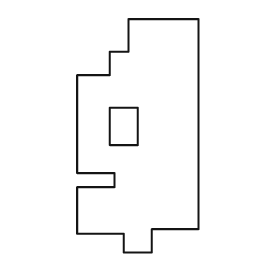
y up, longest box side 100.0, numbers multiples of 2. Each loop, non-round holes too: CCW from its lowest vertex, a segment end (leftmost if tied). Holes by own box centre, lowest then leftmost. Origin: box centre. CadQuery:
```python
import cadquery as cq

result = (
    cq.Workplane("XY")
    .moveTo(-6.0, -50.0)
    .lineTo(6.0, -50.0)
    .lineTo(6.0, -40.0)
    .lineTo(26.0, -40.0)
    .lineTo(26.0, 50.0)
    .lineTo(-4.0, 50.0)
    .lineTo(-4.0, 36.0)
    .lineTo(-12.0, 36.0)
    .lineTo(-12.0, 26.0)
    .lineTo(-26.0, 26.0)
    .lineTo(-26.0, -16.0)
    .lineTo(-10.0, -16.0)
    .lineTo(-10.0, -22.0)
    .lineTo(-26.0, -22.0)
    .lineTo(-26.0, -42.0)
    .lineTo(-6.0, -42.0)
    .close()
    .moveTo(-12.0, -4.0)
    .lineTo(0.0, -4.0)
    .lineTo(0.0, 12.0)
    .lineTo(-12.0, 12.0)
    .close()
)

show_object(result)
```